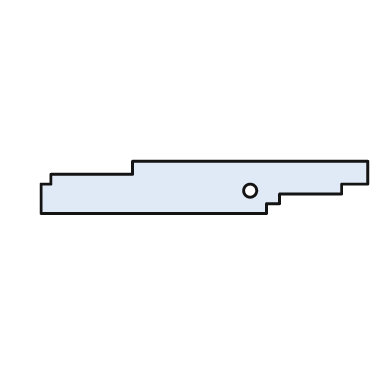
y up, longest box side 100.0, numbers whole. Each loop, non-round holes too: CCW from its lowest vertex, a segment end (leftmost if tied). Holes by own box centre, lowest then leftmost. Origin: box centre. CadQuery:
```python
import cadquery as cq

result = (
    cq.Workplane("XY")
    .moveTo(-50.0, -8.0)
    .lineTo(19.0, -8.0)
    .lineTo(19.0, -5.0)
    .lineTo(23.0, -5.0)
    .lineTo(23.0, -2.0)
    .lineTo(42.0, -2.0)
    .lineTo(42.0, 1.0)
    .lineTo(50.0, 1.0)
    .lineTo(50.0, 8.0)
    .lineTo(-22.0, 8.0)
    .lineTo(-22.0, 4.0)
    .lineTo(-47.0, 4.0)
    .lineTo(-47.0, 1.0)
    .lineTo(-50.0, 1.0)
    .close()
    .moveTo(14.0, -1.0)
    .circle(2.0)
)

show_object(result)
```